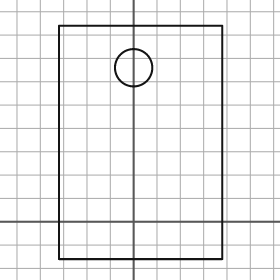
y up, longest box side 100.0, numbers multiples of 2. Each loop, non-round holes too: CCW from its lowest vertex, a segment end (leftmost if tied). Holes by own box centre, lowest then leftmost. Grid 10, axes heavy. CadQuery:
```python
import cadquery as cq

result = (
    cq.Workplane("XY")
    .moveTo(-32.0, -16.0)
    .lineTo(38.0, -16.0)
    .lineTo(38.0, 84.0)
    .lineTo(-32.0, 84.0)
    .close()
    .moveTo(0.0, 66.0)
    .circle(8.0)
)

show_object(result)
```